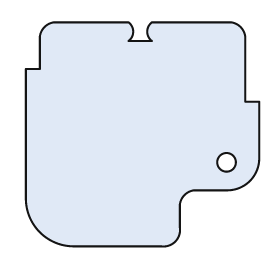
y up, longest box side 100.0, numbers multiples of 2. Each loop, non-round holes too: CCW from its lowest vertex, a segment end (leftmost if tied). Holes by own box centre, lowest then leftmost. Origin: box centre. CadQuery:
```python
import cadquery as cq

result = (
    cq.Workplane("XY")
    .moveTo(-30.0, -48.0)
    .lineTo(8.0, -48.0)
    .threePointArc((14.0, -46.0), (16.0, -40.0))
    .lineTo(16.0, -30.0)
    .threePointArc((18.0, -26.0), (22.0, -24.0))
    .lineTo(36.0, -24.0)
    .threePointArc((46.0, -20.0), (50.0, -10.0))
    .lineTo(50.0, 14.0)
    .lineTo(44.0, 14.0)
    .lineTo(44.0, 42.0)
    .threePointArc((42.0, 46.0), (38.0, 48.0))
    .lineTo(4.0, 48.0)
    .threePointArc((2.0, 44.0), (4.0, 40.0))
    .lineTo(-6.0, 40.0)
    .threePointArc((-4.0, 44.0), (-6.0, 48.0))
    .lineTo(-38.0, 48.0)
    .threePointArc((-42.0, 46.0), (-44.0, 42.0))
    .lineTo(-44.0, 28.0)
    .lineTo(-50.0, 28.0)
    .lineTo(-50.0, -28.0)
    .threePointArc((-44.0, -42.0), (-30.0, -48.0))
    .close()
    .moveTo(36.0, -12.0)
    .circle(4.0)
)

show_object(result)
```